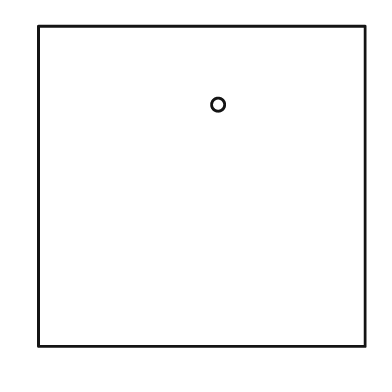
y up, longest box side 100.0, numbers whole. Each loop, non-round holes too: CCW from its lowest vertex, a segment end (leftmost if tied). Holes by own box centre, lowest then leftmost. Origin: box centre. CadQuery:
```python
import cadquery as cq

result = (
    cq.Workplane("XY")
    .moveTo(-50.0, -49.0)
    .lineTo(50.0, -49.0)
    .lineTo(50.0, 49.0)
    .lineTo(-50.0, 49.0)
    .close()
    .moveTo(5.0, 25.0)
    .circle(2.0)
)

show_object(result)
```